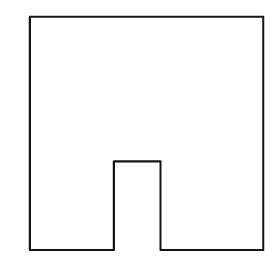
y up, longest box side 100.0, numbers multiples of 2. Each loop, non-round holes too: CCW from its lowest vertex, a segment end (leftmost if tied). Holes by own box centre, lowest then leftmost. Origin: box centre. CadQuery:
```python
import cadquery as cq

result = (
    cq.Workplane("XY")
    .moveTo(-50.0, -50.0)
    .lineTo(-14.0, -50.0)
    .lineTo(-14.0, -12.0)
    .lineTo(6.0, -12.0)
    .lineTo(6.0, -50.0)
    .lineTo(50.0, -50.0)
    .lineTo(50.0, 50.0)
    .lineTo(-50.0, 50.0)
    .close()
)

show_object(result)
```